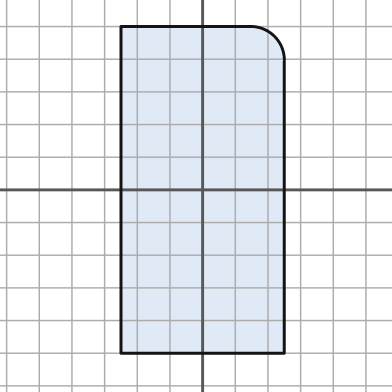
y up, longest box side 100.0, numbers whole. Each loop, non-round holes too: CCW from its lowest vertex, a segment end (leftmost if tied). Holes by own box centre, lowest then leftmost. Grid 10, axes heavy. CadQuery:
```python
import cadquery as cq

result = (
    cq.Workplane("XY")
    .moveTo(-25.0, -50.0)
    .lineTo(25.0, -50.0)
    .lineTo(25.0, 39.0)
    .threePointArc((22.0, 47.0), (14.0, 50.0))
    .lineTo(-25.0, 50.0)
    .close()
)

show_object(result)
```